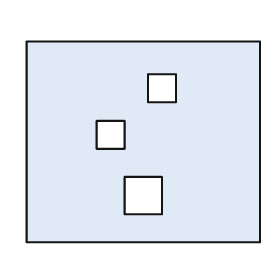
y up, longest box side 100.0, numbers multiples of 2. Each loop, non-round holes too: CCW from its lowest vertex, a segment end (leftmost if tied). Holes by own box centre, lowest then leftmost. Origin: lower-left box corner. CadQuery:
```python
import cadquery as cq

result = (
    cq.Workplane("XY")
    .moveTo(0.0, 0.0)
    .lineTo(100.0, 0.0)
    .lineTo(100.0, 86.0)
    .lineTo(0.0, 86.0)
    .close()
    .moveTo(42.0, 12.0)
    .lineTo(58.0, 12.0)
    .lineTo(58.0, 28.0)
    .lineTo(42.0, 28.0)
    .close()
    .moveTo(30.0, 40.0)
    .lineTo(42.0, 40.0)
    .lineTo(42.0, 52.0)
    .lineTo(30.0, 52.0)
    .close()
    .moveTo(52.0, 60.0)
    .lineTo(64.0, 60.0)
    .lineTo(64.0, 72.0)
    .lineTo(52.0, 72.0)
    .close()
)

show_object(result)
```